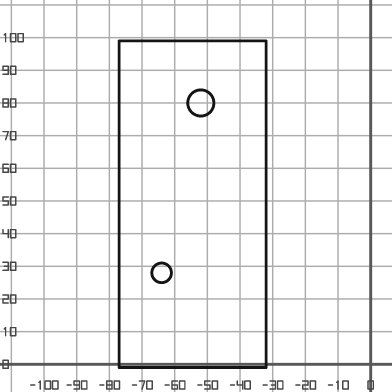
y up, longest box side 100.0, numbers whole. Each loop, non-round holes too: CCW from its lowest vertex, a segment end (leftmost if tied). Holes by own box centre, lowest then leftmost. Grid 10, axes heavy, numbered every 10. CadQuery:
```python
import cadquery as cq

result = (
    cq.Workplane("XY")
    .moveTo(-77.0, -1.0)
    .lineTo(-32.0, -1.0)
    .lineTo(-32.0, 99.0)
    .lineTo(-77.0, 99.0)
    .close()
    .moveTo(-64.0, 28.0)
    .circle(3.0)
    .moveTo(-52.0, 80.0)
    .circle(4.0)
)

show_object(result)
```